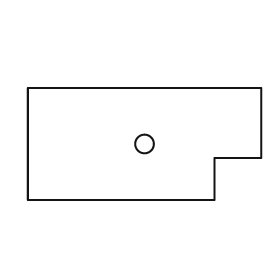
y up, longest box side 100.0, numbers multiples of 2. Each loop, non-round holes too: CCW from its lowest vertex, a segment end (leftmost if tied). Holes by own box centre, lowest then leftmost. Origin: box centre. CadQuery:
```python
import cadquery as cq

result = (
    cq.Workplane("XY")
    .moveTo(-50.0, -24.0)
    .lineTo(30.0, -24.0)
    .lineTo(30.0, -6.0)
    .lineTo(50.0, -6.0)
    .lineTo(50.0, 24.0)
    .lineTo(-50.0, 24.0)
    .close()
    .moveTo(0.0, 0.0)
    .circle(4.0)
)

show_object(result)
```